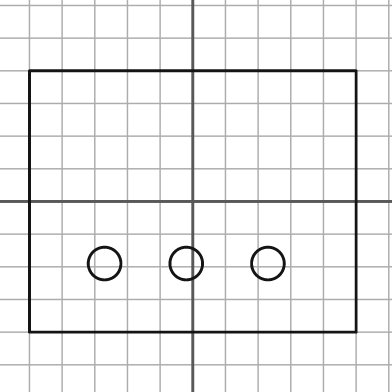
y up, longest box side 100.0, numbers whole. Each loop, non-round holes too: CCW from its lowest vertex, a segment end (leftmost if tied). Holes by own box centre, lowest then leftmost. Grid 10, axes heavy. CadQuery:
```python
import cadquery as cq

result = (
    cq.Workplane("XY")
    .moveTo(-50.0, -40.0)
    .lineTo(50.0, -40.0)
    .lineTo(50.0, 40.0)
    .lineTo(-50.0, 40.0)
    .close()
    .moveTo(-27.0, -19.0)
    .circle(5.0)
    .moveTo(-2.0, -19.0)
    .circle(5.0)
    .moveTo(23.0, -19.0)
    .circle(5.0)
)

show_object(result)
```